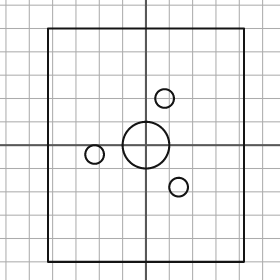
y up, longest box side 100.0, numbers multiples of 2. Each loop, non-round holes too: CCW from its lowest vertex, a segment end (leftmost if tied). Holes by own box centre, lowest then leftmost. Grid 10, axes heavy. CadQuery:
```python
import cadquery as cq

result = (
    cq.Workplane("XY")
    .moveTo(-42.0, -50.0)
    .lineTo(42.0, -50.0)
    .lineTo(42.0, 50.0)
    .lineTo(-42.0, 50.0)
    .close()
    .moveTo(14.0, -18.0)
    .circle(4.0)
    .moveTo(-22.0, -4.0)
    .circle(4.0)
    .moveTo(0.0, 0.0)
    .circle(10.0)
    .moveTo(8.0, 20.0)
    .circle(4.0)
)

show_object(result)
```